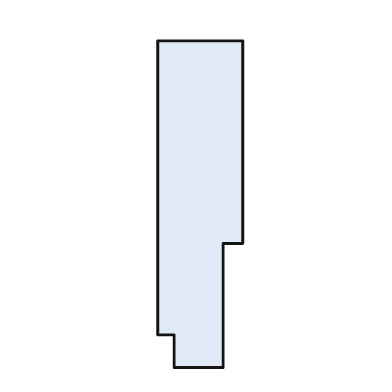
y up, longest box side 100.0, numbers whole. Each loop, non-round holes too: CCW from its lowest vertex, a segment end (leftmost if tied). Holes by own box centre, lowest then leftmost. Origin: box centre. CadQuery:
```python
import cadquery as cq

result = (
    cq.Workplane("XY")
    .moveTo(-8.0, -50.0)
    .lineTo(7.0, -50.0)
    .lineTo(7.0, -12.0)
    .lineTo(13.0, -12.0)
    .lineTo(13.0, 50.0)
    .lineTo(-13.0, 50.0)
    .lineTo(-13.0, -40.0)
    .lineTo(-8.0, -40.0)
    .close()
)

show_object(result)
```